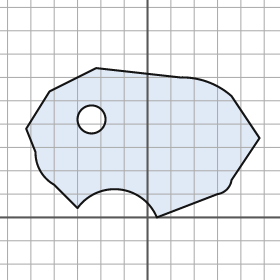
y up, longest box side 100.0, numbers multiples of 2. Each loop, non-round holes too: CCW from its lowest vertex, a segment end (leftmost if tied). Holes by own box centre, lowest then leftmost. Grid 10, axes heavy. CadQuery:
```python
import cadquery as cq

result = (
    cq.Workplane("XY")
    .moveTo(4.0, 0.0)
    .lineTo(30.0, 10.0)
    .threePointArc((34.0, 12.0), (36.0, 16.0))
    .lineTo(48.0, 34.0)
    .lineTo(36.0, 52.0)
    .threePointArc((26.0, 58.0), (14.0, 60.0))
    .lineTo(-22.0, 64.0)
    .lineTo(-42.0, 54.0)
    .lineTo(-52.0, 38.0)
    .lineTo(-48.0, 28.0)
    .threePointArc((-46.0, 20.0), (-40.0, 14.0))
    .lineTo(-30.0, 4.0)
    .threePointArc((-12.0, 12.0), (4.0, 0.0))
    .close()
    .moveTo(-24.0, 42.0)
    .circle(6.0)
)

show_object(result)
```